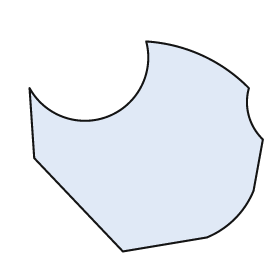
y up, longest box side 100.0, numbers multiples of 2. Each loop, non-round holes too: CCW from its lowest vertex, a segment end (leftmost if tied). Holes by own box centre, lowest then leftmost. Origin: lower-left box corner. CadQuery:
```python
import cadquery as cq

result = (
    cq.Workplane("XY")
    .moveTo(40.0, 0.0)
    .lineTo(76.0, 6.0)
    .threePointArc((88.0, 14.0), (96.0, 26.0))
    .lineTo(100.0, 48.0)
    .threePointArc((94.0, 58.0), (94.0, 70.0))
    .threePointArc((74.0, 84.0), (50.0, 90.0))
    .threePointArc((34.0, 58.0), (0.0, 70.0))
    .lineTo(2.0, 40.0)
    .close()
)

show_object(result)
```